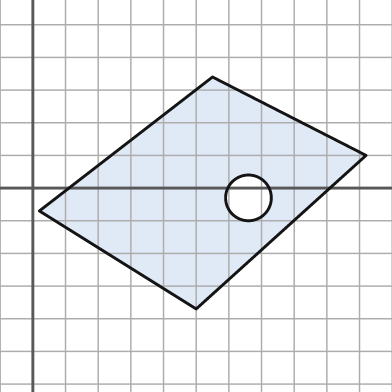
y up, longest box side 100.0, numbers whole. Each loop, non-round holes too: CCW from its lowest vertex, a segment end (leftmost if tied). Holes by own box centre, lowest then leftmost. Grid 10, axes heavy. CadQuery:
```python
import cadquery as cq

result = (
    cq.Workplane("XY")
    .moveTo(50.0, -37.0)
    .lineTo(102.0, 10.0)
    .lineTo(55.0, 34.0)
    .lineTo(2.0, -7.0)
    .close()
    .moveTo(66.0, -3.0)
    .circle(7.0)
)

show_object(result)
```